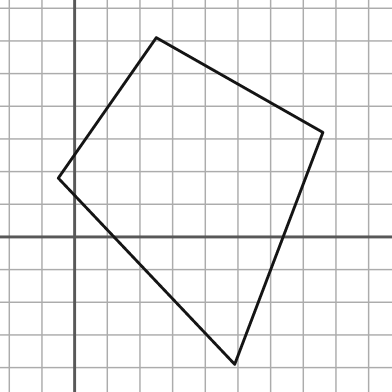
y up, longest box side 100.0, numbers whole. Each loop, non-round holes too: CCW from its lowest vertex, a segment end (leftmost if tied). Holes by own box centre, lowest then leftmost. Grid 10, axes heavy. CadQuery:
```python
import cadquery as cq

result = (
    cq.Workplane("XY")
    .moveTo(49.0, -39.0)
    .lineTo(76.0, 32.0)
    .lineTo(25.0, 61.0)
    .lineTo(-5.0, 18.0)
    .close()
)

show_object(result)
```